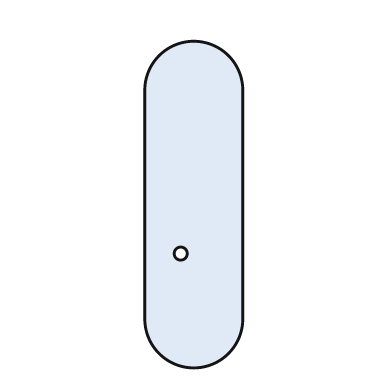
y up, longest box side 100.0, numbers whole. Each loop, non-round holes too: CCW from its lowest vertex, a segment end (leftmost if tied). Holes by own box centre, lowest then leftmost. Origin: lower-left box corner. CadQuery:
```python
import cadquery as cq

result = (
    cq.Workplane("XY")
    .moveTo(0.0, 15.0)
    .threePointArc((15.0, 0.0), (30.0, 15.0))
    .lineTo(30.0, 85.0)
    .threePointArc((15.0, 100.0), (0.0, 85.0))
    .close()
    .moveTo(11.0, 35.0)
    .circle(2.0)
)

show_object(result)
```